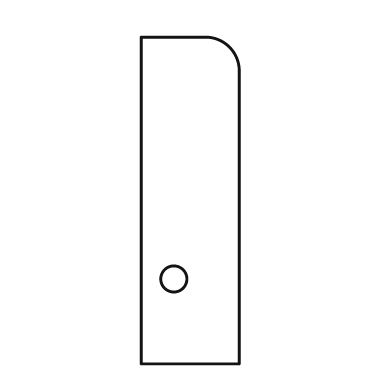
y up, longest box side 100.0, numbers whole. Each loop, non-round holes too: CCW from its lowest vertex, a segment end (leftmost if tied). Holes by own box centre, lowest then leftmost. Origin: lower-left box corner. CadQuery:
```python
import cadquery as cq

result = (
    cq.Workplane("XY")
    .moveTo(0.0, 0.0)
    .lineTo(30.0, 0.0)
    .lineTo(30.0, 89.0)
    .threePointArc((27.0, 97.0), (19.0, 100.0))
    .lineTo(0.0, 100.0)
    .close()
    .moveTo(10.0, 26.0)
    .circle(4.0)
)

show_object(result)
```